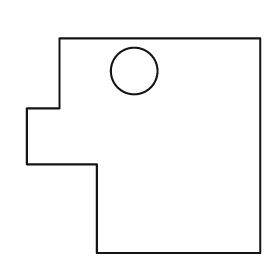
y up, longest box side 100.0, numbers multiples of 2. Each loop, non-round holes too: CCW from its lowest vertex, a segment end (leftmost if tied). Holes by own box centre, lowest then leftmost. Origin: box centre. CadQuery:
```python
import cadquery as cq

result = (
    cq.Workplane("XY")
    .moveTo(-20.0, -46.0)
    .lineTo(50.0, -46.0)
    .lineTo(50.0, 46.0)
    .lineTo(-36.0, 46.0)
    .lineTo(-36.0, 16.0)
    .lineTo(-50.0, 16.0)
    .lineTo(-50.0, -8.0)
    .lineTo(-20.0, -8.0)
    .close()
    .moveTo(-4.0, 32.0)
    .circle(10.0)
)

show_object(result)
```